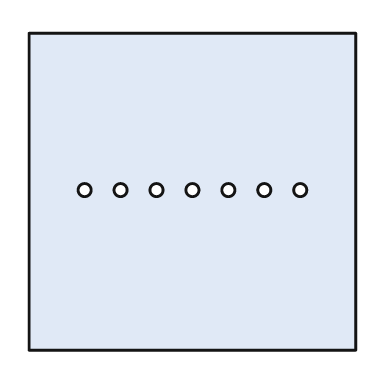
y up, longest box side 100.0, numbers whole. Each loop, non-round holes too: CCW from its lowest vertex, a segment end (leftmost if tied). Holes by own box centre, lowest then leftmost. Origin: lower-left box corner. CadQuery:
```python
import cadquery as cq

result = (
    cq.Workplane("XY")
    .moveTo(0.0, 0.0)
    .lineTo(100.0, 0.0)
    .lineTo(100.0, 97.0)
    .lineTo(0.0, 97.0)
    .close()
    .moveTo(17.0, 49.0)
    .circle(2.0)
    .moveTo(28.0, 49.0)
    .circle(2.0)
    .moveTo(39.0, 49.0)
    .circle(2.0)
    .moveTo(50.0, 49.0)
    .circle(2.0)
    .moveTo(61.0, 49.0)
    .circle(2.0)
    .moveTo(72.0, 49.0)
    .circle(2.0)
    .moveTo(83.0, 49.0)
    .circle(2.0)
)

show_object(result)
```